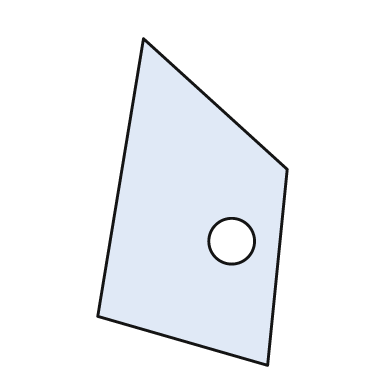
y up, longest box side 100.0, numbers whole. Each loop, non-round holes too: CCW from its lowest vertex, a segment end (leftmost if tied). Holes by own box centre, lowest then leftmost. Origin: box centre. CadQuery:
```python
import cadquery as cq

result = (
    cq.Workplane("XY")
    .moveTo(23.0, -50.0)
    .lineTo(29.0, 10.0)
    .lineTo(-15.0, 50.0)
    .lineTo(-29.0, -35.0)
    .close()
    .moveTo(12.0, -12.0)
    .circle(7.0)
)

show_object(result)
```